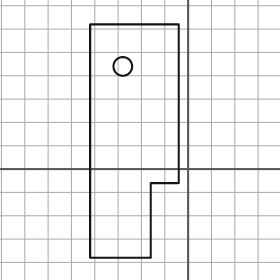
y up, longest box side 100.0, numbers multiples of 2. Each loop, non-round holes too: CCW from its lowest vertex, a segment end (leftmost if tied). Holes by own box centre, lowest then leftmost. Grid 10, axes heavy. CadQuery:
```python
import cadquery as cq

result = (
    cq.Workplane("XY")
    .moveTo(-42.0, -38.0)
    .lineTo(-16.0, -38.0)
    .lineTo(-16.0, -6.0)
    .lineTo(-4.0, -6.0)
    .lineTo(-4.0, 62.0)
    .lineTo(-42.0, 62.0)
    .close()
    .moveTo(-28.0, 44.0)
    .circle(4.0)
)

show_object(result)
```